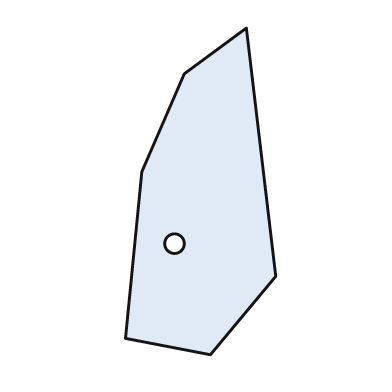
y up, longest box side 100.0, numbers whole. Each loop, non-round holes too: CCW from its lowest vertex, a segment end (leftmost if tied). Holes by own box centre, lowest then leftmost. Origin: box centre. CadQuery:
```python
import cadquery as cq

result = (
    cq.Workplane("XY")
    .moveTo(3.0, -50.0)
    .lineTo(23.0, -26.0)
    .lineTo(14.0, 50.0)
    .lineTo(-5.0, 36.0)
    .lineTo(-18.0, 6.0)
    .lineTo(-23.0, -45.0)
    .close()
    .moveTo(-8.0, -16.0)
    .circle(3.0)
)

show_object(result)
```